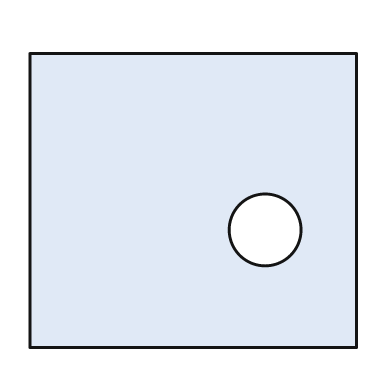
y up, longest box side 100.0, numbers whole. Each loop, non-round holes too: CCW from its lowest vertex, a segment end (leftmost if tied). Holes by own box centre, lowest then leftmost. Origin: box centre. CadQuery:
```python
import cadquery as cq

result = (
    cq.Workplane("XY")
    .moveTo(-50.0, -45.0)
    .lineTo(50.0, -45.0)
    .lineTo(50.0, 45.0)
    .lineTo(-50.0, 45.0)
    .close()
    .moveTo(22.0, -9.0)
    .circle(11.0)
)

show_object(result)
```